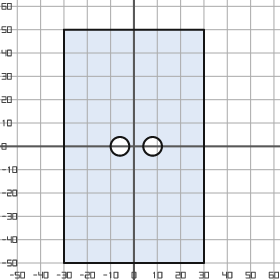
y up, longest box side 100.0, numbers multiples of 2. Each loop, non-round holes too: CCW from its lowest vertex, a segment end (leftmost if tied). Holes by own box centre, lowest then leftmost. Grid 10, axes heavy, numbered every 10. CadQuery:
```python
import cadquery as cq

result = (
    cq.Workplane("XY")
    .moveTo(-30.0, -50.0)
    .lineTo(30.0, -50.0)
    .lineTo(30.0, 50.0)
    .lineTo(-30.0, 50.0)
    .close()
    .moveTo(-6.0, 0.0)
    .circle(4.0)
    .moveTo(8.0, 0.0)
    .circle(4.0)
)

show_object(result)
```